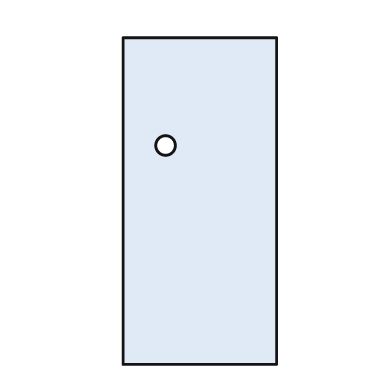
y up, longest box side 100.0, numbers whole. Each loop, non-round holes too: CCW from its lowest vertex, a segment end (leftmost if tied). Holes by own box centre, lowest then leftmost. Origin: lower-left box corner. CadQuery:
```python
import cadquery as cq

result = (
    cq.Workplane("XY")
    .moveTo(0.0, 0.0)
    .lineTo(47.0, 0.0)
    .lineTo(47.0, 100.0)
    .lineTo(0.0, 100.0)
    .close()
    .moveTo(13.0, 67.0)
    .circle(3.0)
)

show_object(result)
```